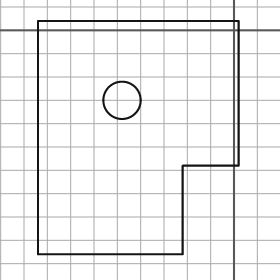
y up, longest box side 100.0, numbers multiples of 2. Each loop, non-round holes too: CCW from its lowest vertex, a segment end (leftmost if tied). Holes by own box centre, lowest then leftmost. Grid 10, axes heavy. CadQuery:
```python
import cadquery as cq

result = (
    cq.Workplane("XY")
    .moveTo(-84.0, -96.0)
    .lineTo(-22.0, -96.0)
    .lineTo(-22.0, -58.0)
    .lineTo(2.0, -58.0)
    .lineTo(2.0, 4.0)
    .lineTo(-84.0, 4.0)
    .close()
    .moveTo(-48.0, -30.0)
    .circle(8.0)
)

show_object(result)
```